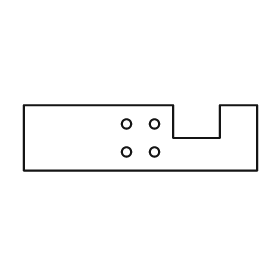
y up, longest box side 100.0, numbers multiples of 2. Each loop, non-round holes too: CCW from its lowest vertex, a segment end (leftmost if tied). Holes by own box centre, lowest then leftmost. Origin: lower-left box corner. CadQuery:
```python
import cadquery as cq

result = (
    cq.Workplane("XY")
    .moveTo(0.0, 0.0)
    .lineTo(100.0, 0.0)
    .lineTo(100.0, 28.0)
    .lineTo(84.0, 28.0)
    .lineTo(84.0, 14.0)
    .lineTo(64.0, 14.0)
    .lineTo(64.0, 28.0)
    .lineTo(0.0, 28.0)
    .close()
    .moveTo(44.0, 8.0)
    .circle(2.0)
    .moveTo(56.0, 8.0)
    .circle(2.0)
    .moveTo(44.0, 20.0)
    .circle(2.0)
    .moveTo(56.0, 20.0)
    .circle(2.0)
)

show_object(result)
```